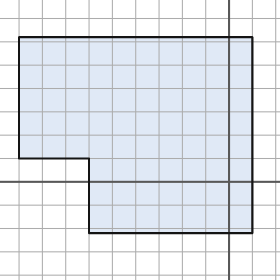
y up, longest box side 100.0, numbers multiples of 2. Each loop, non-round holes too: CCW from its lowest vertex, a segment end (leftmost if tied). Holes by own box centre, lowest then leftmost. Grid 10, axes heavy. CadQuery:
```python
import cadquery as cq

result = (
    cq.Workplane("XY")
    .moveTo(-60.0, -22.0)
    .lineTo(10.0, -22.0)
    .lineTo(10.0, 62.0)
    .lineTo(-90.0, 62.0)
    .lineTo(-90.0, 10.0)
    .lineTo(-60.0, 10.0)
    .close()
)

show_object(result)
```